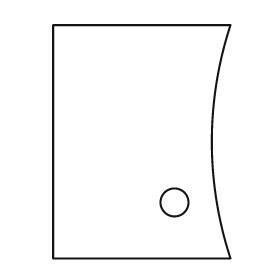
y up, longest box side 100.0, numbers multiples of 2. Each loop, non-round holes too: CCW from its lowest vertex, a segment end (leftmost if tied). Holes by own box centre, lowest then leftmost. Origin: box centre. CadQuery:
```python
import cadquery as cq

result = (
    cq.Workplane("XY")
    .moveTo(-38.0, -50.0)
    .lineTo(38.0, -50.0)
    .threePointArc((30.0, 0.0), (38.0, 50.0))
    .lineTo(-38.0, 50.0)
    .close()
    .moveTo(14.0, -26.0)
    .circle(6.0)
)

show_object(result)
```